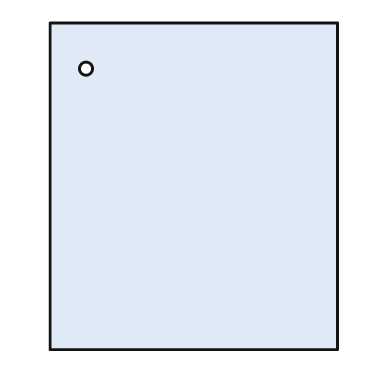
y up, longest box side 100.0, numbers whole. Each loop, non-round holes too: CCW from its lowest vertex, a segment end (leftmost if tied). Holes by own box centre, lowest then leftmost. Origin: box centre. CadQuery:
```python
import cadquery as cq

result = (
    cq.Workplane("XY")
    .moveTo(-44.0, -50.0)
    .lineTo(44.0, -50.0)
    .lineTo(44.0, 50.0)
    .lineTo(-44.0, 50.0)
    .close()
    .moveTo(-33.0, 36.0)
    .circle(2.0)
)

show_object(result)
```